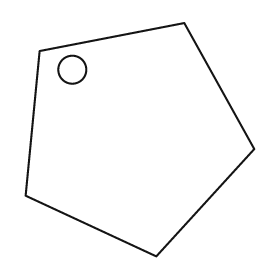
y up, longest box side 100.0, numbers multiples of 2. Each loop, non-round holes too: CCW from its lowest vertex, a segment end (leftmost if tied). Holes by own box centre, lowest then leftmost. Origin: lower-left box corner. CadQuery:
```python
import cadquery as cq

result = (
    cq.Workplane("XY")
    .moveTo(56.0, 0.0)
    .lineTo(98.0, 46.0)
    .lineTo(68.0, 100.0)
    .lineTo(6.0, 88.0)
    .lineTo(0.0, 26.0)
    .close()
    .moveTo(20.0, 80.0)
    .circle(6.0)
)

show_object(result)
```